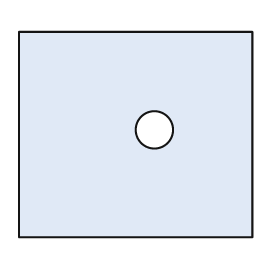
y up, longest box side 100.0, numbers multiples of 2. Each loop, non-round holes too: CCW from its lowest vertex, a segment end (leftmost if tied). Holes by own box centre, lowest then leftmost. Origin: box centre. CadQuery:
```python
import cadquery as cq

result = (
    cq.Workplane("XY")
    .moveTo(-50.0, -44.0)
    .lineTo(50.0, -44.0)
    .lineTo(50.0, 44.0)
    .lineTo(-50.0, 44.0)
    .close()
    .moveTo(8.0, 2.0)
    .circle(8.0)
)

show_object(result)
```